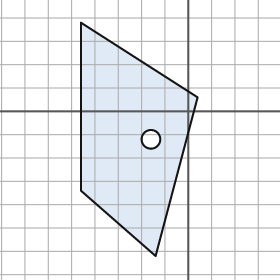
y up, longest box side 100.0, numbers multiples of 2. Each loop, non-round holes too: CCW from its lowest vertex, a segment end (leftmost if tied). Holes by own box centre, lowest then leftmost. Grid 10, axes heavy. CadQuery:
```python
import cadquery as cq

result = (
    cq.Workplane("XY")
    .moveTo(-14.0, -62.0)
    .lineTo(4.0, 6.0)
    .lineTo(-46.0, 38.0)
    .lineTo(-46.0, -34.0)
    .close()
    .moveTo(-16.0, -12.0)
    .circle(4.0)
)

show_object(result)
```